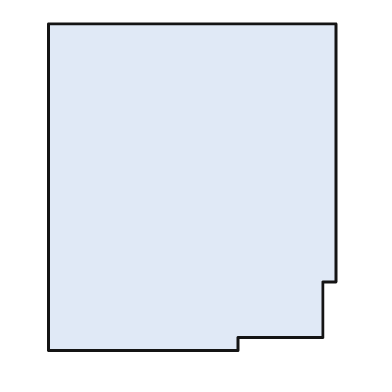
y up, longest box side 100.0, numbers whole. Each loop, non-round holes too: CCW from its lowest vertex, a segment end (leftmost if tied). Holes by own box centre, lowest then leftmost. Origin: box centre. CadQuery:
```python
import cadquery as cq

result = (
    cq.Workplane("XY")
    .moveTo(-44.0, -50.0)
    .lineTo(14.0, -50.0)
    .lineTo(14.0, -46.0)
    .lineTo(40.0, -46.0)
    .lineTo(40.0, -29.0)
    .lineTo(44.0, -29.0)
    .lineTo(44.0, 50.0)
    .lineTo(-44.0, 50.0)
    .close()
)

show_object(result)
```